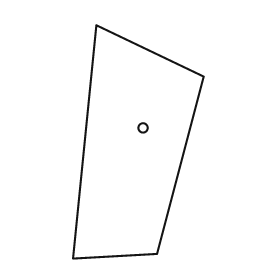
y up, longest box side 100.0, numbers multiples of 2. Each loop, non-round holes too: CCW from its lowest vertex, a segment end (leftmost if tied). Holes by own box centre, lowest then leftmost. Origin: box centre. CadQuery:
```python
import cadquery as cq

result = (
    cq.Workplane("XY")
    .moveTo(-28.0, -50.0)
    .lineTo(8.0, -48.0)
    .lineTo(28.0, 28.0)
    .lineTo(-18.0, 50.0)
    .close()
    .moveTo(2.0, 6.0)
    .circle(2.0)
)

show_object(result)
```